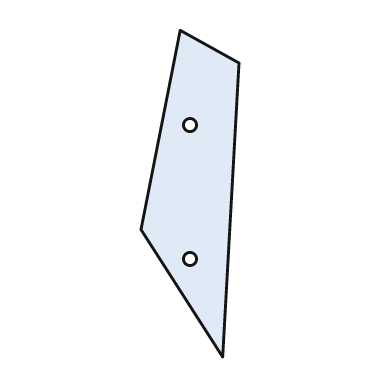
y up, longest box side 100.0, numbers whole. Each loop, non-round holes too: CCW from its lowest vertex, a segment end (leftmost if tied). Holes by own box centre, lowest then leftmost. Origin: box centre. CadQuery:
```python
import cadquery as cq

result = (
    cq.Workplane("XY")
    .moveTo(10.0, -50.0)
    .lineTo(15.0, 40.0)
    .lineTo(-3.0, 50.0)
    .lineTo(-15.0, -11.0)
    .close()
    .moveTo(0.0, -20.0)
    .circle(2.0)
    .moveTo(0.0, 21.0)
    .circle(2.0)
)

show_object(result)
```